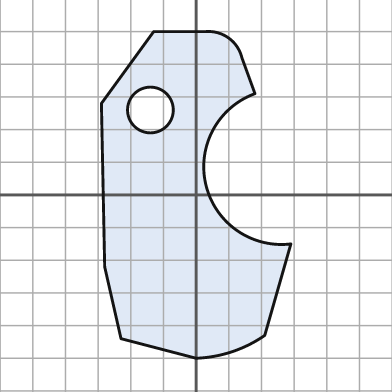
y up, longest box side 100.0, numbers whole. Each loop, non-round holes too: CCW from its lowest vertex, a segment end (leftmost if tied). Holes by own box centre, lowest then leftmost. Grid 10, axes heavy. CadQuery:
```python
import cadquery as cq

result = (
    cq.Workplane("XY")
    .moveTo(0.0, -50.0)
    .threePointArc((11.0, -48.0), (21.0, -43.0))
    .lineTo(29.0, -15.0)
    .threePointArc((3.0, 3.0), (18.0, 31.0))
    .lineTo(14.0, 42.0)
    .threePointArc((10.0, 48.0), (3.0, 50.0))
    .lineTo(-13.0, 50.0)
    .lineTo(-29.0, 28.0)
    .lineTo(-28.0, -22.0)
    .lineTo(-23.0, -44.0)
    .close()
    .moveTo(-14.0, 26.0)
    .circle(7.0)
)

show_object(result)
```